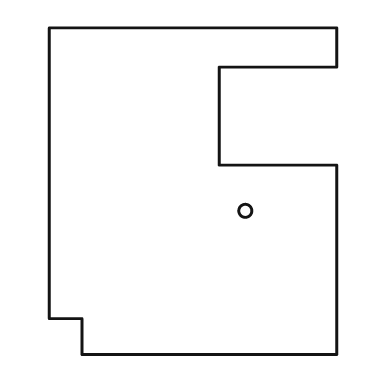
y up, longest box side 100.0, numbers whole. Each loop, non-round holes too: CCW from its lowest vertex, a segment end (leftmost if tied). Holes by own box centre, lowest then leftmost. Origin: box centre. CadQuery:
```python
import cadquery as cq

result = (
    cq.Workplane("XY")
    .moveTo(-34.0, -50.0)
    .lineTo(44.0, -50.0)
    .lineTo(44.0, 8.0)
    .lineTo(8.0, 8.0)
    .lineTo(8.0, 38.0)
    .lineTo(44.0, 38.0)
    .lineTo(44.0, 50.0)
    .lineTo(-44.0, 50.0)
    .lineTo(-44.0, -39.0)
    .lineTo(-34.0, -39.0)
    .close()
    .moveTo(16.0, -6.0)
    .circle(2.0)
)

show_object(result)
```